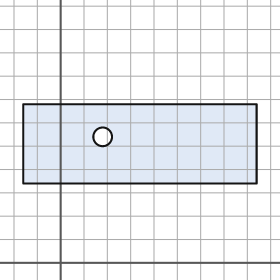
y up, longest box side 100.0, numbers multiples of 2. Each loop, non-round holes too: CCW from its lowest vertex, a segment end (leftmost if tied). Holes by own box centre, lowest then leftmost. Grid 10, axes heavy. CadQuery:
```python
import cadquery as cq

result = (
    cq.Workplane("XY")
    .moveTo(-16.0, 34.0)
    .lineTo(84.0, 34.0)
    .lineTo(84.0, 68.0)
    .lineTo(-16.0, 68.0)
    .close()
    .moveTo(18.0, 54.0)
    .circle(4.0)
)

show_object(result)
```